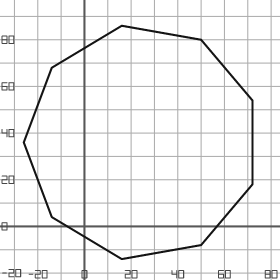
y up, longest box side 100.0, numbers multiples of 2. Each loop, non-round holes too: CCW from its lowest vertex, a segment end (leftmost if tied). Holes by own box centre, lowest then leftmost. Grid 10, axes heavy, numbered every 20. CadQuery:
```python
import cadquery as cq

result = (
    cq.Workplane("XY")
    .moveTo(16.0, -14.0)
    .lineTo(50.0, -8.0)
    .lineTo(72.0, 18.0)
    .lineTo(72.0, 54.0)
    .lineTo(50.0, 80.0)
    .lineTo(16.0, 86.0)
    .lineTo(-14.0, 68.0)
    .lineTo(-26.0, 36.0)
    .lineTo(-14.0, 4.0)
    .close()
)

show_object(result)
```